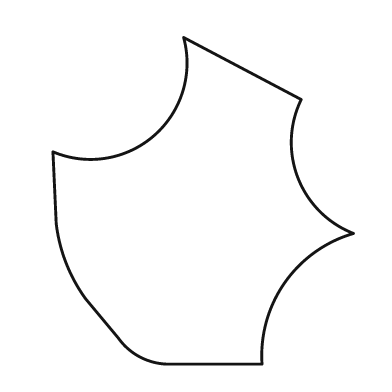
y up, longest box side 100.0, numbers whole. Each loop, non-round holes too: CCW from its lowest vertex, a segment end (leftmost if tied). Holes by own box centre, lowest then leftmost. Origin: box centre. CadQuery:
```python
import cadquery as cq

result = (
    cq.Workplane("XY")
    .moveTo(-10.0, -50.0)
    .lineTo(18.0, -50.0)
    .threePointArc((25.0, -25.0), (46.0, -10.0))
    .threePointArc((29.0, 7.0), (30.0, 31.0))
    .lineTo(-6.0, 50.0)
    .threePointArc((-15.0, 20.0), (-46.0, 15.0))
    .lineTo(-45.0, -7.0)
    .threePointArc((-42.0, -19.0), (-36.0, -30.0))
    .lineTo(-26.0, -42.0)
    .threePointArc((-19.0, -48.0), (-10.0, -50.0))
    .close()
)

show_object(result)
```